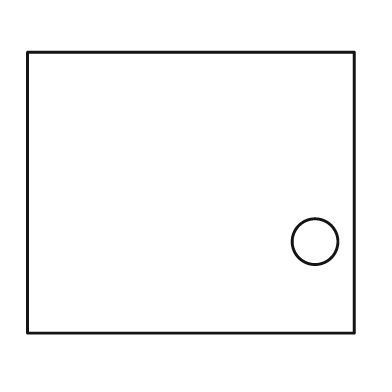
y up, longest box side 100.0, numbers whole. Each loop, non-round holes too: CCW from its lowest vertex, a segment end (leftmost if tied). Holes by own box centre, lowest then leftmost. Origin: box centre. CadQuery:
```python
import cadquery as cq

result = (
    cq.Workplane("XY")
    .moveTo(-50.0, -43.0)
    .lineTo(50.0, -43.0)
    .lineTo(50.0, 43.0)
    .lineTo(-50.0, 43.0)
    .close()
    .moveTo(38.0, -15.0)
    .circle(7.0)
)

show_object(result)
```